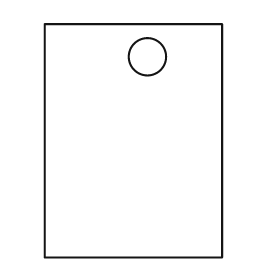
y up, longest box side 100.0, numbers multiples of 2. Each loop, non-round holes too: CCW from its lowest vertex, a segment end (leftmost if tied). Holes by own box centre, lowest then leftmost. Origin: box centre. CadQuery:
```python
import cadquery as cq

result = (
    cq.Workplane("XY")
    .moveTo(-38.0, -50.0)
    .lineTo(38.0, -50.0)
    .lineTo(38.0, 50.0)
    .lineTo(-38.0, 50.0)
    .close()
    .moveTo(6.0, 36.0)
    .circle(8.0)
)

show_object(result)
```